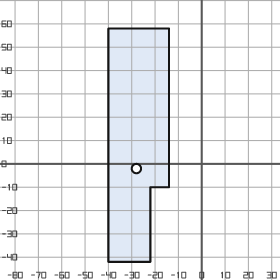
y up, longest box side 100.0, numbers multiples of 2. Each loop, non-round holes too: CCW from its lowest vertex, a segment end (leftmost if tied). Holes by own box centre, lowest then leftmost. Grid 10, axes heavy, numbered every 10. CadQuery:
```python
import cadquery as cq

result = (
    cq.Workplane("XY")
    .moveTo(-40.0, -42.0)
    .lineTo(-22.0, -42.0)
    .lineTo(-22.0, -10.0)
    .lineTo(-14.0, -10.0)
    .lineTo(-14.0, 58.0)
    .lineTo(-40.0, 58.0)
    .close()
    .moveTo(-28.0, -2.0)
    .circle(2.0)
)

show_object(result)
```